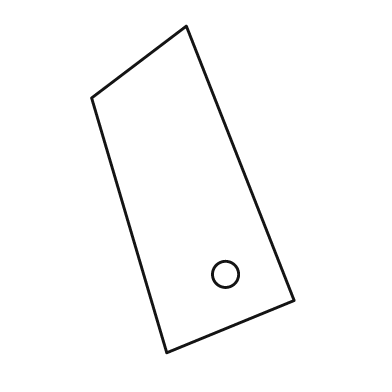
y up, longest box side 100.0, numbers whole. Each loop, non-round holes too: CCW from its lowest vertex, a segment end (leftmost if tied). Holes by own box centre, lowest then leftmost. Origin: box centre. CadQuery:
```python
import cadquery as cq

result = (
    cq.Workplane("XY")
    .moveTo(-8.0, -50.0)
    .lineTo(31.0, -34.0)
    .lineTo(-2.0, 50.0)
    .lineTo(-31.0, 28.0)
    .close()
    .moveTo(10.0, -26.0)
    .circle(4.0)
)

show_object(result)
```